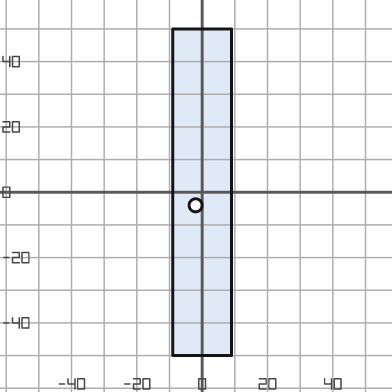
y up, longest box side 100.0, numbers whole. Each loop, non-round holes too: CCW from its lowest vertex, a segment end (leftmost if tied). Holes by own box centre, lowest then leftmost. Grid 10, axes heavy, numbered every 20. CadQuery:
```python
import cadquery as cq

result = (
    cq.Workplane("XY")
    .moveTo(-9.0, -50.0)
    .lineTo(9.0, -50.0)
    .lineTo(9.0, 50.0)
    .lineTo(-9.0, 50.0)
    .close()
    .moveTo(-2.0, -4.0)
    .circle(2.0)
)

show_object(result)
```